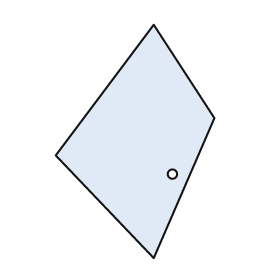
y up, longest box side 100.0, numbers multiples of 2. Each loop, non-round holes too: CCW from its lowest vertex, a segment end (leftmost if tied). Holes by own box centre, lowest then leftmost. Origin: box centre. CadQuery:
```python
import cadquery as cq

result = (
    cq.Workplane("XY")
    .moveTo(8.0, -50.0)
    .lineTo(34.0, 10.0)
    .lineTo(8.0, 50.0)
    .lineTo(-34.0, -6.0)
    .close()
    .moveTo(16.0, -14.0)
    .circle(2.0)
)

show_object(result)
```